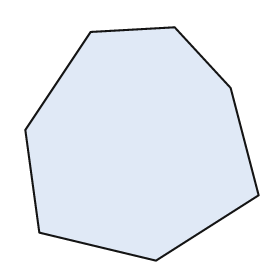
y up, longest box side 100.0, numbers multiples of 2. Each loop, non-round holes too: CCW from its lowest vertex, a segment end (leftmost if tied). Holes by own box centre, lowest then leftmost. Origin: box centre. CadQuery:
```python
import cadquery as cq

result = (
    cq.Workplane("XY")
    .moveTo(6.0, -50.0)
    .lineTo(50.0, -22.0)
    .lineTo(38.0, 24.0)
    .lineTo(14.0, 50.0)
    .lineTo(-22.0, 48.0)
    .lineTo(-50.0, 6.0)
    .lineTo(-44.0, -38.0)
    .close()
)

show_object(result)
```